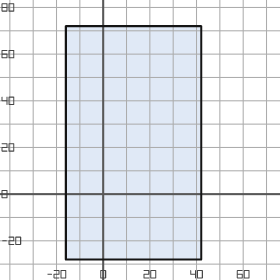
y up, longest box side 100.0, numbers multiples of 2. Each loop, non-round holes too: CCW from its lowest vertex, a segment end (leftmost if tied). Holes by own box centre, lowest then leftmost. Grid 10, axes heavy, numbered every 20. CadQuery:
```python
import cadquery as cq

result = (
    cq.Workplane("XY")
    .moveTo(-16.0, -28.0)
    .lineTo(42.0, -28.0)
    .lineTo(42.0, 72.0)
    .lineTo(-16.0, 72.0)
    .close()
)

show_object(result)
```